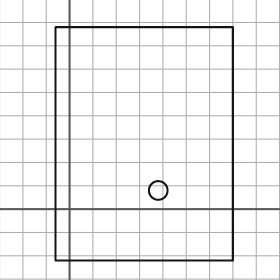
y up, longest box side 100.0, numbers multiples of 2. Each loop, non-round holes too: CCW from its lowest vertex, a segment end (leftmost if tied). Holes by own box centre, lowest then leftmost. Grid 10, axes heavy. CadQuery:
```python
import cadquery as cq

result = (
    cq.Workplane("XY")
    .moveTo(-6.0, -22.0)
    .lineTo(70.0, -22.0)
    .lineTo(70.0, 78.0)
    .lineTo(-6.0, 78.0)
    .close()
    .moveTo(38.0, 8.0)
    .circle(4.0)
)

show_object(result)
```